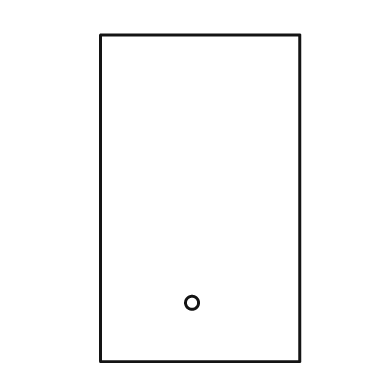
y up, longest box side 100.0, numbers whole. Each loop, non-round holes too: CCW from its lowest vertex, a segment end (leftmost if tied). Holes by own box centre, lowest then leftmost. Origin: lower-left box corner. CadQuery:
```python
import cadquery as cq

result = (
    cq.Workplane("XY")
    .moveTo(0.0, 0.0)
    .lineTo(61.0, 0.0)
    .lineTo(61.0, 100.0)
    .lineTo(0.0, 100.0)
    .close()
    .moveTo(28.0, 18.0)
    .circle(2.0)
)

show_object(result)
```